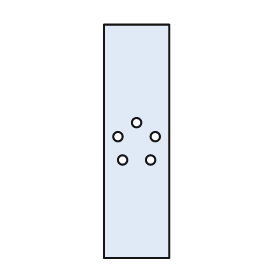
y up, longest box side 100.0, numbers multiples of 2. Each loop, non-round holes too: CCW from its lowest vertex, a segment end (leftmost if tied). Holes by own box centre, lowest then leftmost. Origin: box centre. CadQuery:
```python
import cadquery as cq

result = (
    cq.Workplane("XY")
    .moveTo(-14.0, -50.0)
    .lineTo(14.0, -50.0)
    .lineTo(14.0, 50.0)
    .lineTo(-14.0, 50.0)
    .close()
    .moveTo(-6.0, -8.0)
    .circle(2.0)
    .moveTo(6.0, -8.0)
    .circle(2.0)
    .moveTo(-8.0, 2.0)
    .circle(2.0)
    .moveTo(8.0, 2.0)
    .circle(2.0)
    .moveTo(0.0, 8.0)
    .circle(2.0)
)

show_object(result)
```